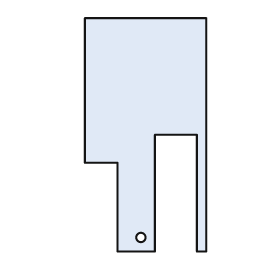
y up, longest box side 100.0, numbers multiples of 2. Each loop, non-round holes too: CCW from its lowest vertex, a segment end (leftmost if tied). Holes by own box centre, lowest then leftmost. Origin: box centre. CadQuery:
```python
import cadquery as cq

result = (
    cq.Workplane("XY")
    .moveTo(-12.0, -50.0)
    .lineTo(4.0, -50.0)
    .lineTo(4.0, 0.0)
    .lineTo(22.0, 0.0)
    .lineTo(22.0, -50.0)
    .lineTo(26.0, -50.0)
    .lineTo(26.0, 50.0)
    .lineTo(-26.0, 50.0)
    .lineTo(-26.0, -12.0)
    .lineTo(-12.0, -12.0)
    .close()
    .moveTo(-2.0, -44.0)
    .circle(2.0)
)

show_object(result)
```